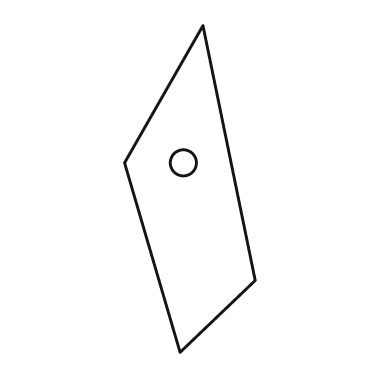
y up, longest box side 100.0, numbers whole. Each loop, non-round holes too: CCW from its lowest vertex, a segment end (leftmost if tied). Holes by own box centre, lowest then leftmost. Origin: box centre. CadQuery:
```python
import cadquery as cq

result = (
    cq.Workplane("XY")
    .moveTo(-3.0, -50.0)
    .lineTo(20.0, -28.0)
    .lineTo(4.0, 50.0)
    .lineTo(-20.0, 8.0)
    .close()
    .moveTo(-2.0, 8.0)
    .circle(4.0)
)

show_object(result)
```